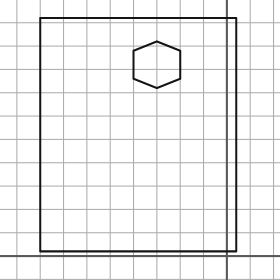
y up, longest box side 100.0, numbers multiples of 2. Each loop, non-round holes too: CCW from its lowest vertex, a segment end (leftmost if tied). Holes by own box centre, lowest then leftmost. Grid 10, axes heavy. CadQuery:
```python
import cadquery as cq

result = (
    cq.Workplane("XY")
    .moveTo(-80.0, 2.0)
    .lineTo(4.0, 2.0)
    .lineTo(4.0, 102.0)
    .lineTo(-80.0, 102.0)
    .close()
    .moveTo(-30.0, 72.0)
    .lineTo(-20.0, 76.0)
    .lineTo(-20.0, 88.0)
    .lineTo(-30.0, 92.0)
    .lineTo(-40.0, 88.0)
    .lineTo(-40.0, 76.0)
    .close()
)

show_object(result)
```